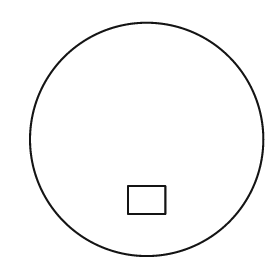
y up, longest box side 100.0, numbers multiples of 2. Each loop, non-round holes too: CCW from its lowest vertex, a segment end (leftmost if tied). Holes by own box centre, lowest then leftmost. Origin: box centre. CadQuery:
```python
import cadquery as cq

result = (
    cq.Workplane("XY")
    .moveTo(0.0, 0.0)
    .circle(50.0)
    .moveTo(-8.0, -32.0)
    .lineTo(8.0, -32.0)
    .lineTo(8.0, -20.0)
    .lineTo(-8.0, -20.0)
    .close()
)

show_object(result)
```